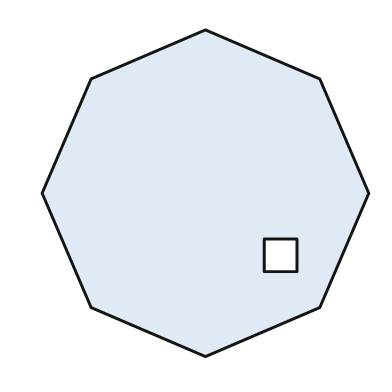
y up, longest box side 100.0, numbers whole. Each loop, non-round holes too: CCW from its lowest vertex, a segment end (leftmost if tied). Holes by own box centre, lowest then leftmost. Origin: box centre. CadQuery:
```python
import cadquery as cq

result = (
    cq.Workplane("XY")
    .moveTo(0.0, -50.0)
    .lineTo(35.0, -35.0)
    .lineTo(50.0, 0.0)
    .lineTo(35.0, 35.0)
    .lineTo(0.0, 50.0)
    .lineTo(-35.0, 35.0)
    .lineTo(-50.0, 0.0)
    .lineTo(-35.0, -35.0)
    .close()
    .moveTo(18.0, -24.0)
    .lineTo(28.0, -24.0)
    .lineTo(28.0, -14.0)
    .lineTo(18.0, -14.0)
    .close()
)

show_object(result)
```